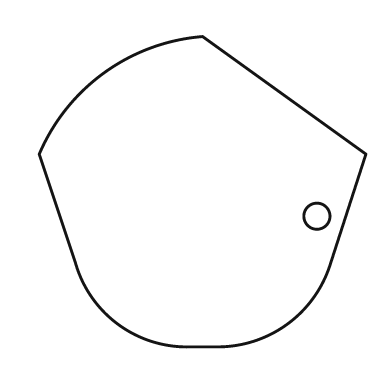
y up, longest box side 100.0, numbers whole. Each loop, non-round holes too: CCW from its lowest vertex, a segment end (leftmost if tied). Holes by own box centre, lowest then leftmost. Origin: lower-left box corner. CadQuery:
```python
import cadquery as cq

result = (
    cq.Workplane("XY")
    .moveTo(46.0, 0.0)
    .lineTo(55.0, 0.0)
    .threePointArc((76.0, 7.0), (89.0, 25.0))
    .lineTo(100.0, 59.0)
    .lineTo(50.0, 95.0)
    .threePointArc((20.0, 84.0), (0.0, 59.0))
    .lineTo(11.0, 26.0)
    .threePointArc((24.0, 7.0), (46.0, 0.0))
    .close()
    .moveTo(85.0, 40.0)
    .circle(4.0)
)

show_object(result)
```